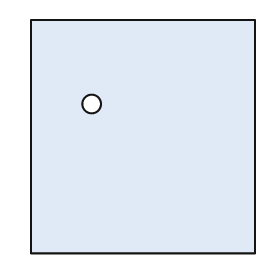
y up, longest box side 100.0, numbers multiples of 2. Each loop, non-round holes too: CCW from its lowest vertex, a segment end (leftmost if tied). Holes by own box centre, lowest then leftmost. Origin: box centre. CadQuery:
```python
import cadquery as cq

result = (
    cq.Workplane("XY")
    .moveTo(-48.0, -50.0)
    .lineTo(48.0, -50.0)
    .lineTo(48.0, 50.0)
    .lineTo(-48.0, 50.0)
    .close()
    .moveTo(-22.0, 14.0)
    .circle(4.0)
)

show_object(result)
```